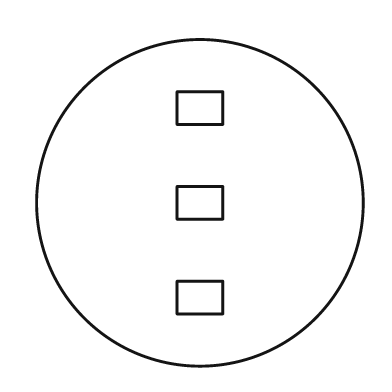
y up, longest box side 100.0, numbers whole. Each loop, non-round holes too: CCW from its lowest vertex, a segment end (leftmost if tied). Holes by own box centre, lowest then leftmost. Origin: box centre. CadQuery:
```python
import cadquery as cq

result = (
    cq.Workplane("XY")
    .moveTo(0.0, 0.0)
    .circle(50.0)
    .moveTo(-7.0, -34.0)
    .lineTo(7.0, -34.0)
    .lineTo(7.0, -24.0)
    .lineTo(-7.0, -24.0)
    .close()
    .moveTo(-7.0, -5.0)
    .lineTo(7.0, -5.0)
    .lineTo(7.0, 5.0)
    .lineTo(-7.0, 5.0)
    .close()
    .moveTo(-7.0, 24.0)
    .lineTo(7.0, 24.0)
    .lineTo(7.0, 34.0)
    .lineTo(-7.0, 34.0)
    .close()
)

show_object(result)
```